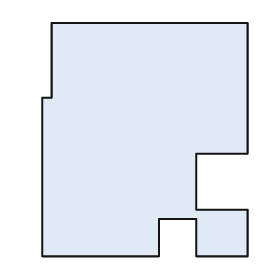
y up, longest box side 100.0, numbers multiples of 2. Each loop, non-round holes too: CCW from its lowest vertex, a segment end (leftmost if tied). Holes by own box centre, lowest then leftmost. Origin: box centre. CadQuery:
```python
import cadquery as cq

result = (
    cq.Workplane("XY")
    .moveTo(-44.0, -50.0)
    .lineTo(6.0, -50.0)
    .lineTo(6.0, -34.0)
    .lineTo(22.0, -34.0)
    .lineTo(22.0, -50.0)
    .lineTo(44.0, -50.0)
    .lineTo(44.0, -30.0)
    .lineTo(22.0, -30.0)
    .lineTo(22.0, -6.0)
    .lineTo(44.0, -6.0)
    .lineTo(44.0, 50.0)
    .lineTo(-40.0, 50.0)
    .lineTo(-40.0, 18.0)
    .lineTo(-44.0, 18.0)
    .close()
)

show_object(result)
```